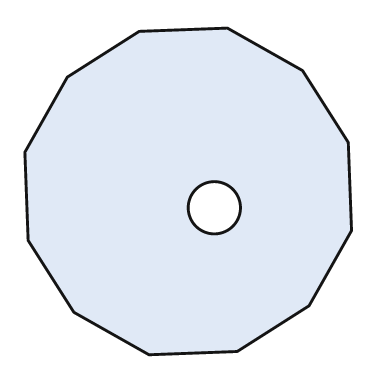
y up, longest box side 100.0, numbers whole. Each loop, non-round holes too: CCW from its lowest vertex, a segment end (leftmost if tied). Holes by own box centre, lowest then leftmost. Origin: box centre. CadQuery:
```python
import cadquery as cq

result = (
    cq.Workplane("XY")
    .moveTo(-12.0, -50.0)
    .lineTo(15.0, -49.0)
    .lineTo(37.0, -35.0)
    .lineTo(50.0, -12.0)
    .lineTo(49.0, 15.0)
    .lineTo(35.0, 37.0)
    .lineTo(12.0, 50.0)
    .lineTo(-15.0, 49.0)
    .lineTo(-37.0, 35.0)
    .lineTo(-50.0, 12.0)
    .lineTo(-49.0, -15.0)
    .lineTo(-35.0, -37.0)
    .close()
    .moveTo(8.0, -5.0)
    .circle(8.0)
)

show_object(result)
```